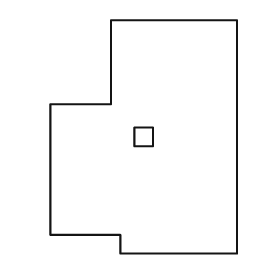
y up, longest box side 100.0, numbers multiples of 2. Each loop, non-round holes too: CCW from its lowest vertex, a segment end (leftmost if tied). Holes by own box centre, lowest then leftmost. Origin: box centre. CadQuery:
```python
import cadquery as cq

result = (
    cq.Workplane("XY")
    .moveTo(-10.0, -50.0)
    .lineTo(40.0, -50.0)
    .lineTo(40.0, 50.0)
    .lineTo(-14.0, 50.0)
    .lineTo(-14.0, 14.0)
    .lineTo(-40.0, 14.0)
    .lineTo(-40.0, -42.0)
    .lineTo(-10.0, -42.0)
    .close()
    .moveTo(-4.0, -4.0)
    .lineTo(4.0, -4.0)
    .lineTo(4.0, 4.0)
    .lineTo(-4.0, 4.0)
    .close()
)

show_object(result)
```